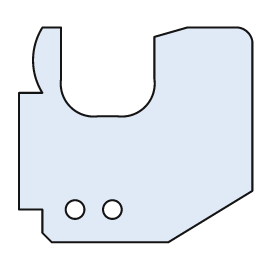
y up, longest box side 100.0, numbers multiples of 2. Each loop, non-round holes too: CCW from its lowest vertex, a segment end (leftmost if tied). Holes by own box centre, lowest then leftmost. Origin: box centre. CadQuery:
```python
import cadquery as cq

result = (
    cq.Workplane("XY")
    .moveTo(-36.0, -46.0)
    .lineTo(14.0, -46.0)
    .lineTo(50.0, -24.0)
    .lineTo(50.0, 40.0)
    .threePointArc((48.0, 44.0), (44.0, 46.0))
    .lineTo(22.0, 46.0)
    .lineTo(8.0, 42.0)
    .lineTo(8.0, 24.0)
    .threePointArc((4.0, 12.0), (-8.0, 8.0))
    .lineTo(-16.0, 8.0)
    .threePointArc((-28.0, 12.0), (-32.0, 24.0))
    .lineTo(-32.0, 46.0)
    .lineTo(-40.0, 46.0)
    .threePointArc((-44.0, 32.0), (-40.0, 18.0))
    .lineTo(-50.0, 18.0)
    .lineTo(-50.0, -32.0)
    .lineTo(-40.0, -32.0)
    .lineTo(-40.0, -42.0)
    .close()
    .moveTo(-26.0, -32.0)
    .circle(4.0)
    .moveTo(-10.0, -32.0)
    .circle(4.0)
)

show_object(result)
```